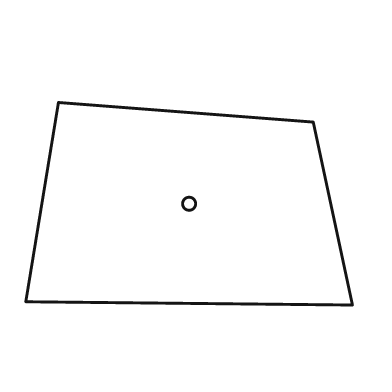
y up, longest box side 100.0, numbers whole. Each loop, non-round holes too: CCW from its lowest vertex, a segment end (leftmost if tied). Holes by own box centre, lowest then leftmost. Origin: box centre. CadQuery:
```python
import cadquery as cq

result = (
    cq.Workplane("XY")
    .moveTo(50.0, -31.0)
    .lineTo(38.0, 25.0)
    .lineTo(-40.0, 31.0)
    .lineTo(-50.0, -30.0)
    .close()
    .moveTo(0.0, 0.0)
    .circle(2.0)
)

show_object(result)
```